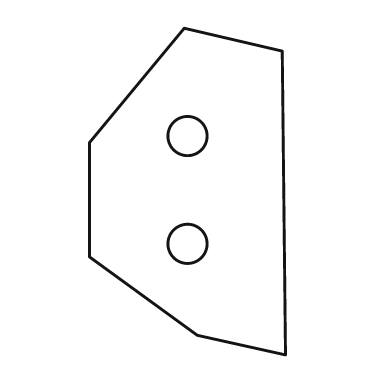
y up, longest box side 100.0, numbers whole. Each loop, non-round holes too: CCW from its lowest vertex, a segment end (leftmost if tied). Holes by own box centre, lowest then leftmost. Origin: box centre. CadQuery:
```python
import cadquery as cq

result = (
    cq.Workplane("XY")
    .moveTo(30.0, -50.0)
    .lineTo(29.0, 43.0)
    .lineTo(-1.0, 50.0)
    .lineTo(-30.0, 15.0)
    .lineTo(-30.0, -20.0)
    .lineTo(3.0, -44.0)
    .close()
    .moveTo(0.0, -16.0)
    .circle(6.0)
    .moveTo(0.0, 17.0)
    .circle(6.0)
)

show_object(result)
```